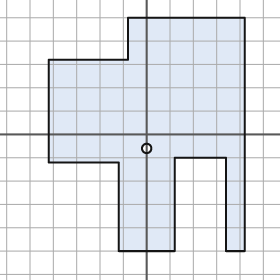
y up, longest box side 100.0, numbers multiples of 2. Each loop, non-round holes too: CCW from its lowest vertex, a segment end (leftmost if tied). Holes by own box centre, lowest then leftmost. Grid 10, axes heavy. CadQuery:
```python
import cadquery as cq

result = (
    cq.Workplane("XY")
    .moveTo(-12.0, -50.0)
    .lineTo(12.0, -50.0)
    .lineTo(12.0, -10.0)
    .lineTo(34.0, -10.0)
    .lineTo(34.0, -50.0)
    .lineTo(42.0, -50.0)
    .lineTo(42.0, 50.0)
    .lineTo(-8.0, 50.0)
    .lineTo(-8.0, 32.0)
    .lineTo(-42.0, 32.0)
    .lineTo(-42.0, -12.0)
    .lineTo(-12.0, -12.0)
    .close()
    .moveTo(0.0, -6.0)
    .circle(2.0)
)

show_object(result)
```